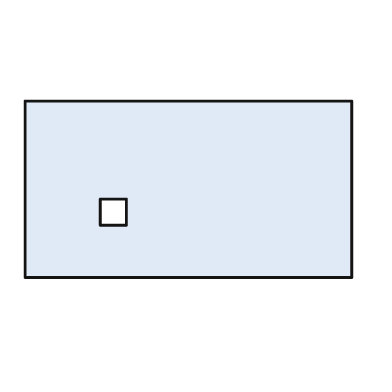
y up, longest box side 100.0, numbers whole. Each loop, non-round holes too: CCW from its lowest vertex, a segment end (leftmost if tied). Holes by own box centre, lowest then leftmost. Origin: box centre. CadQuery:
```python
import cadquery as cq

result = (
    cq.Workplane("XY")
    .moveTo(-50.0, -27.0)
    .lineTo(50.0, -27.0)
    .lineTo(50.0, 27.0)
    .lineTo(-50.0, 27.0)
    .close()
    .moveTo(-27.0, -11.0)
    .lineTo(-19.0, -11.0)
    .lineTo(-19.0, -3.0)
    .lineTo(-27.0, -3.0)
    .close()
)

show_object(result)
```